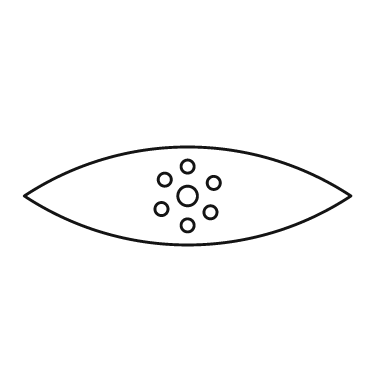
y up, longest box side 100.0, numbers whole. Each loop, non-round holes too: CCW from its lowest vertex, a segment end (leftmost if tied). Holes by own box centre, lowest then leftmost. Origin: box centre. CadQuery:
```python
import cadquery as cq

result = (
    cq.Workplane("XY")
    .moveTo(-50.0, 0.0)
    .threePointArc((0.0, -15.0), (50.0, 0.0))
    .threePointArc((0.0, 15.0), (-50.0, 0.0))
    .close()
    .moveTo(0.0, -9.0)
    .circle(2.0)
    .moveTo(7.0, -5.0)
    .circle(2.0)
    .moveTo(-8.0, -4.0)
    .circle(2.0)
    .moveTo(0.0, 0.0)
    .circle(3.0)
    .moveTo(8.0, 4.0)
    .circle(2.0)
    .moveTo(-7.0, 5.0)
    .circle(2.0)
    .moveTo(0.0, 9.0)
    .circle(2.0)
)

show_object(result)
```